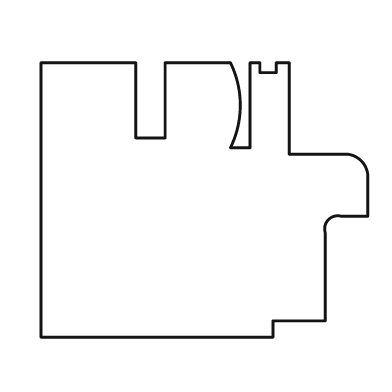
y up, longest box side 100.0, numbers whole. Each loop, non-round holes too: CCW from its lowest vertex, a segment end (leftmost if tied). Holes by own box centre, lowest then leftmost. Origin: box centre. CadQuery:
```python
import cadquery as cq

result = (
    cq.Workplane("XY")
    .moveTo(-50.0, -42.0)
    .lineTo(21.0, -42.0)
    .lineTo(21.0, -37.0)
    .lineTo(37.0, -37.0)
    .lineTo(37.0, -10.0)
    .threePointArc((38.0, -6.0), (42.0, -5.0))
    .lineTo(50.0, -5.0)
    .lineTo(50.0, 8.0)
    .threePointArc((48.0, 12.0), (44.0, 14.0))
    .lineTo(26.0, 14.0)
    .lineTo(26.0, 42.0)
    .lineTo(22.0, 42.0)
    .lineTo(22.0, 39.0)
    .lineTo(17.0, 39.0)
    .lineTo(17.0, 42.0)
    .lineTo(14.0, 42.0)
    .lineTo(14.0, 16.0)
    .lineTo(8.0, 16.0)
    .threePointArc((11.0, 29.0), (8.0, 42.0))
    .lineTo(-12.0, 42.0)
    .lineTo(-12.0, 19.0)
    .lineTo(-21.0, 19.0)
    .lineTo(-21.0, 42.0)
    .lineTo(-50.0, 42.0)
    .close()
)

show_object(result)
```